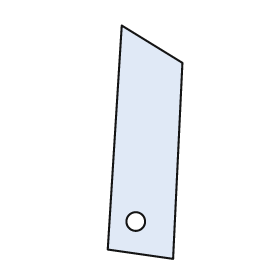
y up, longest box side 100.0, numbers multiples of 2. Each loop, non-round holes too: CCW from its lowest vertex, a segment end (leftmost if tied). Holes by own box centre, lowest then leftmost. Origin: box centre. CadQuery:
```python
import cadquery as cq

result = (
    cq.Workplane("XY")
    .moveTo(12.0, -50.0)
    .lineTo(16.0, 34.0)
    .lineTo(-10.0, 50.0)
    .lineTo(-16.0, -46.0)
    .close()
    .moveTo(-4.0, -34.0)
    .circle(4.0)
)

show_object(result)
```